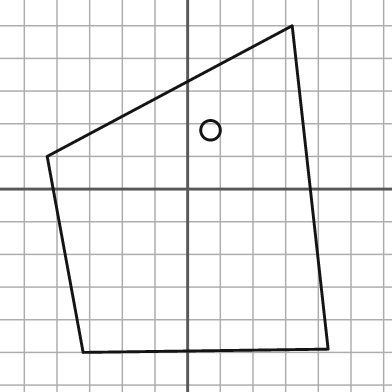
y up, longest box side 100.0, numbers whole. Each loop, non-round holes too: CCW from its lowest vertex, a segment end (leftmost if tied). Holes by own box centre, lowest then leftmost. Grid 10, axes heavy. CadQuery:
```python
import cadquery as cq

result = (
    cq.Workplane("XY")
    .moveTo(-32.0, -50.0)
    .lineTo(43.0, -49.0)
    .lineTo(32.0, 50.0)
    .lineTo(-43.0, 10.0)
    .close()
    .moveTo(7.0, 18.0)
    .circle(3.0)
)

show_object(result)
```